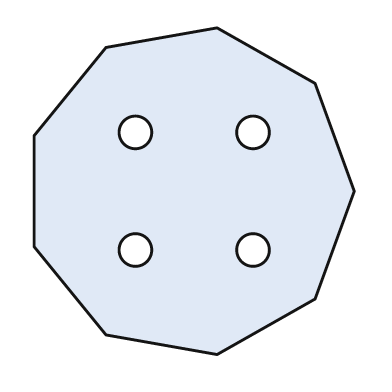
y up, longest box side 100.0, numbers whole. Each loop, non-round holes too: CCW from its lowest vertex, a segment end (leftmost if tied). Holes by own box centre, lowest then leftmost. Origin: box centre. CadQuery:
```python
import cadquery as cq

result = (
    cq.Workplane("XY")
    .moveTo(7.0, -50.0)
    .lineTo(37.0, -33.0)
    .lineTo(49.0, 0.0)
    .lineTo(37.0, 33.0)
    .lineTo(7.0, 50.0)
    .lineTo(-27.0, 44.0)
    .lineTo(-49.0, 17.0)
    .lineTo(-49.0, -17.0)
    .lineTo(-27.0, -44.0)
    .close()
    .moveTo(-18.0, -18.0)
    .circle(5.0)
    .moveTo(18.0, -18.0)
    .circle(5.0)
    .moveTo(-18.0, 18.0)
    .circle(5.0)
    .moveTo(18.0, 18.0)
    .circle(5.0)
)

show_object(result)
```